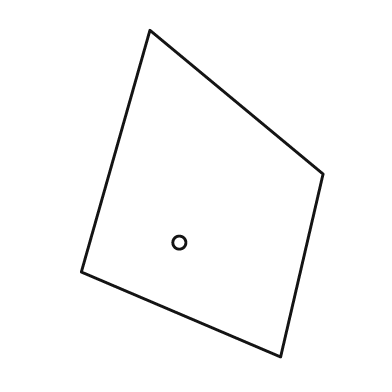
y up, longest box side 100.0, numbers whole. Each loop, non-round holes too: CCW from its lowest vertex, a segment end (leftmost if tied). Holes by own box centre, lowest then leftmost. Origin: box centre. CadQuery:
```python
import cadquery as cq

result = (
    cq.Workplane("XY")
    .moveTo(24.0, -50.0)
    .lineTo(37.0, 6.0)
    .lineTo(-16.0, 50.0)
    .lineTo(-37.0, -24.0)
    .close()
    .moveTo(-7.0, -15.0)
    .circle(2.0)
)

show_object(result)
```